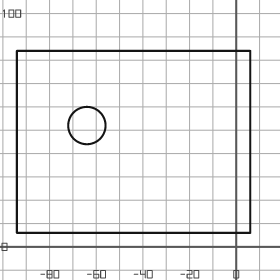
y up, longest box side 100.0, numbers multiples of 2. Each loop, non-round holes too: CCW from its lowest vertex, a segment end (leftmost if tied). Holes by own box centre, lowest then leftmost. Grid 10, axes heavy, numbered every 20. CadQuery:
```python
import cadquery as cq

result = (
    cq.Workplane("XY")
    .moveTo(-94.0, 6.0)
    .lineTo(6.0, 6.0)
    .lineTo(6.0, 84.0)
    .lineTo(-94.0, 84.0)
    .close()
    .moveTo(-64.0, 52.0)
    .circle(8.0)
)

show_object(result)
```